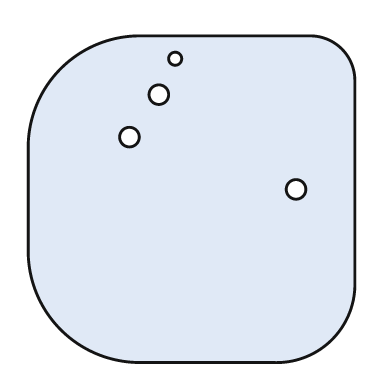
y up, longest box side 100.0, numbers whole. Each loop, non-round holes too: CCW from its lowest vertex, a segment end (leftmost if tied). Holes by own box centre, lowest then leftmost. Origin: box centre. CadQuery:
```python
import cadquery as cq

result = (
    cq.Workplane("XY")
    .moveTo(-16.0, -50.0)
    .lineTo(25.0, -50.0)
    .threePointArc((43.0, -43.0), (50.0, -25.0))
    .lineTo(50.0, 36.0)
    .threePointArc((46.0, 46.0), (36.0, 50.0))
    .lineTo(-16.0, 50.0)
    .threePointArc((-40.0, 40.0), (-50.0, 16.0))
    .lineTo(-50.0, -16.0)
    .threePointArc((-40.0, -40.0), (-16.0, -50.0))
    .close()
    .moveTo(32.0, 3.0)
    .circle(3.0)
    .moveTo(-19.0, 19.0)
    .circle(3.0)
    .moveTo(-10.0, 32.0)
    .circle(3.0)
    .moveTo(-5.0, 43.0)
    .circle(2.0)
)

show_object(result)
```